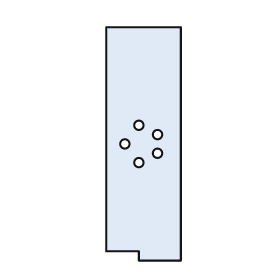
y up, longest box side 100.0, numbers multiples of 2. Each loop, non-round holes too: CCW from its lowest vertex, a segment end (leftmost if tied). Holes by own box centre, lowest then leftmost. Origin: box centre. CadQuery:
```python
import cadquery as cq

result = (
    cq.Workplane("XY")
    .moveTo(-2.0, -50.0)
    .lineTo(16.0, -50.0)
    .lineTo(16.0, 50.0)
    .lineTo(-16.0, 50.0)
    .lineTo(-16.0, -46.0)
    .lineTo(-2.0, -46.0)
    .close()
    .moveTo(-2.0, -8.0)
    .circle(2.0)
    .moveTo(6.0, -4.0)
    .circle(2.0)
    .moveTo(-8.0, 0.0)
    .circle(2.0)
    .moveTo(6.0, 4.0)
    .circle(2.0)
    .moveTo(-2.0, 8.0)
    .circle(2.0)
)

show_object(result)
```